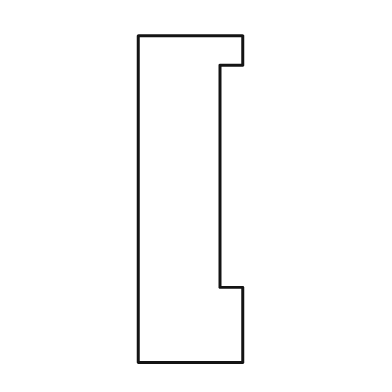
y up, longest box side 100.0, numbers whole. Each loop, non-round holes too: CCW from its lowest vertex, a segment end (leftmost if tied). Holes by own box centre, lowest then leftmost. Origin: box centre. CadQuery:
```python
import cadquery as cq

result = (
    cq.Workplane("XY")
    .moveTo(-16.0, -50.0)
    .lineTo(16.0, -50.0)
    .lineTo(16.0, -27.0)
    .lineTo(9.0, -27.0)
    .lineTo(9.0, 41.0)
    .lineTo(16.0, 41.0)
    .lineTo(16.0, 50.0)
    .lineTo(-16.0, 50.0)
    .close()
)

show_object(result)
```